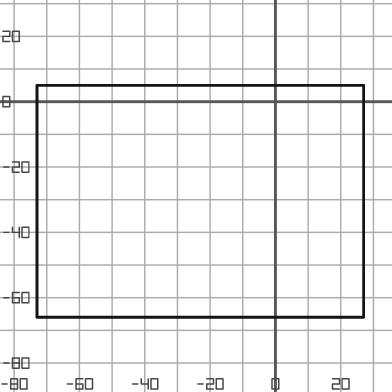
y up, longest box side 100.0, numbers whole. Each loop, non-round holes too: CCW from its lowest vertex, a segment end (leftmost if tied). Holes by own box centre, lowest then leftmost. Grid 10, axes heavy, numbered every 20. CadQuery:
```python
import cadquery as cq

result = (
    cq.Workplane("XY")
    .moveTo(-73.0, -66.0)
    .lineTo(27.0, -66.0)
    .lineTo(27.0, 5.0)
    .lineTo(-73.0, 5.0)
    .close()
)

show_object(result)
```